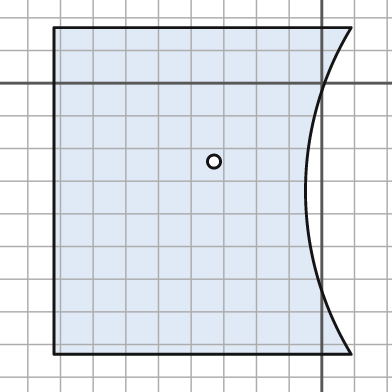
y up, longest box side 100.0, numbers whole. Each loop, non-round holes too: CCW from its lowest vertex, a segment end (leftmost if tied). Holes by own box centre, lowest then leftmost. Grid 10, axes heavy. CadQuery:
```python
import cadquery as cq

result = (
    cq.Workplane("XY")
    .moveTo(-82.0, -83.0)
    .lineTo(9.0, -83.0)
    .threePointArc((-5.0, -33.0), (9.0, 17.0))
    .lineTo(-82.0, 17.0)
    .close()
    .moveTo(-33.0, -24.0)
    .circle(2.0)
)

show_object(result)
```